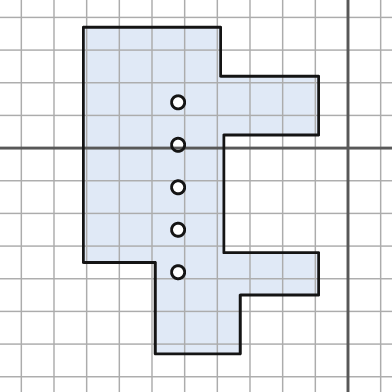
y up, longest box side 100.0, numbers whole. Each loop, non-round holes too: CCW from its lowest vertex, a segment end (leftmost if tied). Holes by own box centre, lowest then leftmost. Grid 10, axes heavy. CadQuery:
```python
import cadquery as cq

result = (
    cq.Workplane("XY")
    .moveTo(-59.0, -63.0)
    .lineTo(-33.0, -63.0)
    .lineTo(-33.0, -45.0)
    .lineTo(-9.0, -45.0)
    .lineTo(-9.0, -32.0)
    .lineTo(-38.0, -32.0)
    .lineTo(-38.0, 4.0)
    .lineTo(-9.0, 4.0)
    .lineTo(-9.0, 22.0)
    .lineTo(-39.0, 22.0)
    .lineTo(-39.0, 37.0)
    .lineTo(-81.0, 37.0)
    .lineTo(-81.0, -35.0)
    .lineTo(-59.0, -35.0)
    .close()
    .moveTo(-52.0, -38.0)
    .circle(2.0)
    .moveTo(-52.0, -25.0)
    .circle(2.0)
    .moveTo(-52.0, -12.0)
    .circle(2.0)
    .moveTo(-52.0, 1.0)
    .circle(2.0)
    .moveTo(-52.0, 14.0)
    .circle(2.0)
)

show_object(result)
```